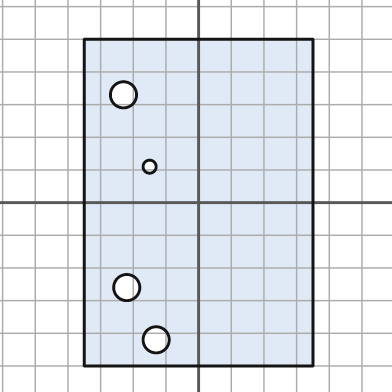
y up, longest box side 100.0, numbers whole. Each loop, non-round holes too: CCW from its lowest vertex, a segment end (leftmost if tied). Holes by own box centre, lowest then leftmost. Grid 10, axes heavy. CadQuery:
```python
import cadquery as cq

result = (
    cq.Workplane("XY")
    .moveTo(-35.0, -50.0)
    .lineTo(35.0, -50.0)
    .lineTo(35.0, 50.0)
    .lineTo(-35.0, 50.0)
    .close()
    .moveTo(-13.0, -42.0)
    .circle(4.0)
    .moveTo(-22.0, -26.0)
    .circle(4.0)
    .moveTo(-15.0, 11.0)
    .circle(2.0)
    .moveTo(-23.0, 33.0)
    .circle(4.0)
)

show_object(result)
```